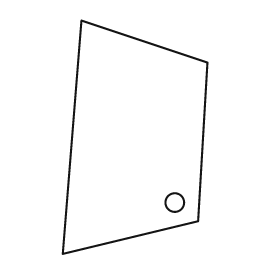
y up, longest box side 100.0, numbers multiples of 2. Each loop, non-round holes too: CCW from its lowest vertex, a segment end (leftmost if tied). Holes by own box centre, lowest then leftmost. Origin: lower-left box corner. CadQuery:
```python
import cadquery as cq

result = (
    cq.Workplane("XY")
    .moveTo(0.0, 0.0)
    .lineTo(58.0, 14.0)
    .lineTo(62.0, 82.0)
    .lineTo(8.0, 100.0)
    .close()
    .moveTo(48.0, 22.0)
    .circle(4.0)
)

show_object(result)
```